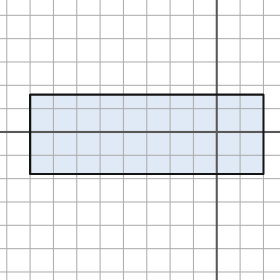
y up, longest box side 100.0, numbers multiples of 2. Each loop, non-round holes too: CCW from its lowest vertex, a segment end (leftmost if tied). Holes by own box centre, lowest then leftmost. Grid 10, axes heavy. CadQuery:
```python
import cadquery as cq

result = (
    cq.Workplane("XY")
    .moveTo(-80.0, -18.0)
    .lineTo(20.0, -18.0)
    .lineTo(20.0, 16.0)
    .lineTo(-80.0, 16.0)
    .close()
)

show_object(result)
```